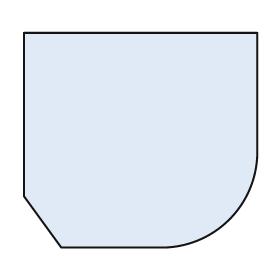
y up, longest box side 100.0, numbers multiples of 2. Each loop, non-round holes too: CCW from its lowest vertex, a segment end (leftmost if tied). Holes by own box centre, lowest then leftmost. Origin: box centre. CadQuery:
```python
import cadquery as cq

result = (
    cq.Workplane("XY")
    .moveTo(-34.0, -46.0)
    .lineTo(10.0, -46.0)
    .threePointArc((38.0, -34.0), (50.0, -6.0))
    .lineTo(50.0, 46.0)
    .lineTo(-50.0, 46.0)
    .lineTo(-50.0, -24.0)
    .close()
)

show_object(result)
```